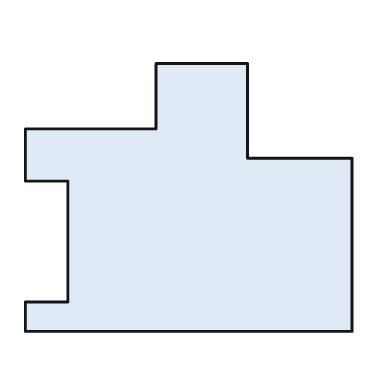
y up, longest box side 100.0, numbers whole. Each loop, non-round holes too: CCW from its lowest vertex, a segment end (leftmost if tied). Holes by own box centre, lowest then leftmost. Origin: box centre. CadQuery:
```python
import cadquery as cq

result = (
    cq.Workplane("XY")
    .moveTo(-50.0, -41.0)
    .lineTo(50.0, -41.0)
    .lineTo(50.0, 12.0)
    .lineTo(18.0, 12.0)
    .lineTo(18.0, 41.0)
    .lineTo(-10.0, 41.0)
    .lineTo(-10.0, 21.0)
    .lineTo(-50.0, 21.0)
    .lineTo(-50.0, 5.0)
    .lineTo(-37.0, 5.0)
    .lineTo(-37.0, -32.0)
    .lineTo(-50.0, -32.0)
    .close()
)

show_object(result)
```